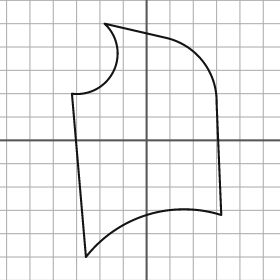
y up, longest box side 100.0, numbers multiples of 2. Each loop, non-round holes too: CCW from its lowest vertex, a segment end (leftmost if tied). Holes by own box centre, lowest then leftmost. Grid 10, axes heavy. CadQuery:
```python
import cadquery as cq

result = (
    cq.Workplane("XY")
    .moveTo(-26.0, -50.0)
    .threePointArc((0.0, -32.0), (32.0, -32.0))
    .lineTo(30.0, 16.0)
    .threePointArc((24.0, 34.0), (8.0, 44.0))
    .lineTo(-18.0, 50.0)
    .threePointArc((-14.0, 30.0), (-32.0, 20.0))
    .close()
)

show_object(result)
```